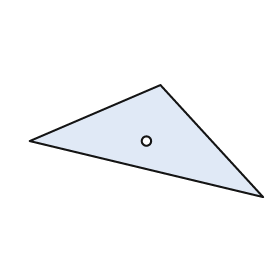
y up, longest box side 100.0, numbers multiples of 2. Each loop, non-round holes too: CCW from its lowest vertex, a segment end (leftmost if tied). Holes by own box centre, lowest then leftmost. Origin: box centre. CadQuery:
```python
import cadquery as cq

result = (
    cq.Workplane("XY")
    .moveTo(50.0, -24.0)
    .lineTo(6.0, 24.0)
    .lineTo(-50.0, 0.0)
    .close()
    .moveTo(0.0, 0.0)
    .circle(2.0)
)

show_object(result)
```